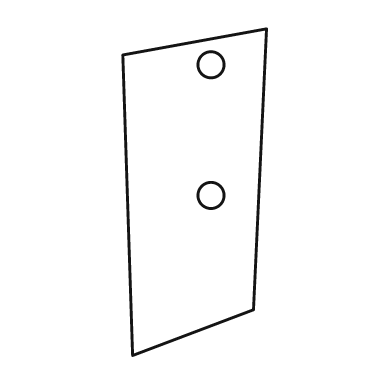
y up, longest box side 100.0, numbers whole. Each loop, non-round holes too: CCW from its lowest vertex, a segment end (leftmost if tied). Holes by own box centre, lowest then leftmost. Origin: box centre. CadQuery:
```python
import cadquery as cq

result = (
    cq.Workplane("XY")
    .moveTo(-19.0, -50.0)
    .lineTo(18.0, -36.0)
    .lineTo(22.0, 50.0)
    .lineTo(-22.0, 42.0)
    .close()
    .moveTo(5.0, -1.0)
    .circle(4.0)
    .moveTo(5.0, 39.0)
    .circle(4.0)
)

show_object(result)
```